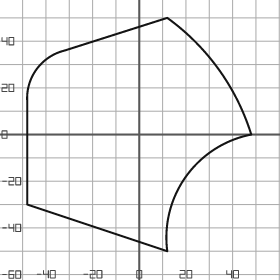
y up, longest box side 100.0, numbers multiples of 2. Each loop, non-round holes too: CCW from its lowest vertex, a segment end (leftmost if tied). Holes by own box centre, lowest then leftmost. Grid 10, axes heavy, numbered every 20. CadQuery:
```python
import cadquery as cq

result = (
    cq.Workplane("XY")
    .moveTo(12.0, -50.0)
    .threePointArc((20.0, -18.0), (48.0, 0.0))
    .threePointArc((34.0, 28.0), (12.0, 50.0))
    .lineTo(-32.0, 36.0)
    .threePointArc((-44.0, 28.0), (-48.0, 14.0))
    .lineTo(-48.0, -30.0)
    .close()
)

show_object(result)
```